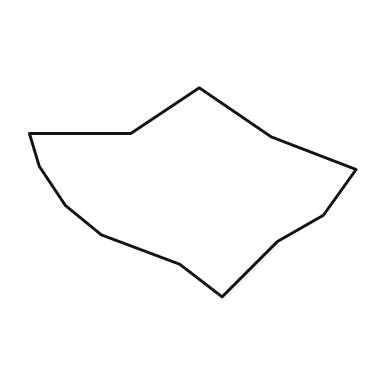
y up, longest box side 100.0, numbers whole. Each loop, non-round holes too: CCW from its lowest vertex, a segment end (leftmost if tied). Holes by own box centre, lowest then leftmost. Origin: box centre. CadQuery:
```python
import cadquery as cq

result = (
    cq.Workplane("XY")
    .moveTo(9.0, -32.0)
    .lineTo(26.0, -15.0)
    .lineTo(40.0, -7.0)
    .lineTo(50.0, 7.0)
    .lineTo(24.0, 17.0)
    .lineTo(2.0, 32.0)
    .lineTo(-19.0, 18.0)
    .lineTo(-50.0, 18.0)
    .lineTo(-47.0, 8.0)
    .lineTo(-39.0, -4.0)
    .lineTo(-28.0, -13.0)
    .lineTo(-4.0, -22.0)
    .close()
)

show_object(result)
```